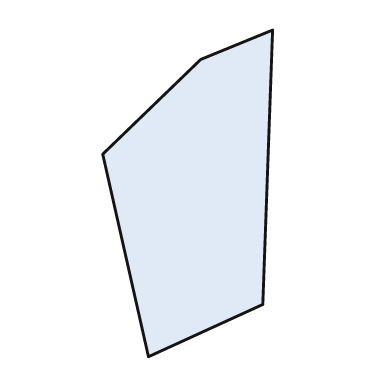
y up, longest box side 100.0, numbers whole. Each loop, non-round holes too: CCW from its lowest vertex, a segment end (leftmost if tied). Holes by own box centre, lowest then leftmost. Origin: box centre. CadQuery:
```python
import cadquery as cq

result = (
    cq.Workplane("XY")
    .moveTo(-12.0, -50.0)
    .lineTo(23.0, -34.0)
    .lineTo(26.0, 50.0)
    .lineTo(4.0, 41.0)
    .lineTo(-26.0, 12.0)
    .close()
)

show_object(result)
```